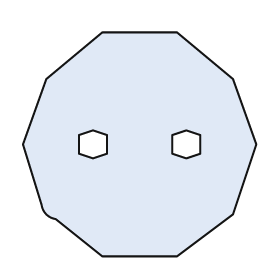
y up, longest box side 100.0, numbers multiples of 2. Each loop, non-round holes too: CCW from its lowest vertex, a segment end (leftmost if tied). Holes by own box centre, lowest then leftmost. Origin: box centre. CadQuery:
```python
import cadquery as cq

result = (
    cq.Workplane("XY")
    .moveTo(-16.0, -48.0)
    .lineTo(16.0, -48.0)
    .lineTo(40.0, -30.0)
    .lineTo(50.0, 0.0)
    .lineTo(40.0, 28.0)
    .lineTo(16.0, 48.0)
    .lineTo(-16.0, 48.0)
    .lineTo(-40.0, 28.0)
    .lineTo(-50.0, 0.0)
    .lineTo(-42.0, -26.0)
    .threePointArc((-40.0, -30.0), (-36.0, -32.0))
    .close()
    .moveTo(-20.0, -6.0)
    .lineTo(-14.0, -4.0)
    .lineTo(-14.0, 4.0)
    .lineTo(-20.0, 6.0)
    .lineTo(-26.0, 4.0)
    .lineTo(-26.0, -4.0)
    .close()
    .moveTo(20.0, -6.0)
    .lineTo(26.0, -4.0)
    .lineTo(26.0, 4.0)
    .lineTo(20.0, 6.0)
    .lineTo(14.0, 4.0)
    .lineTo(14.0, -4.0)
    .close()
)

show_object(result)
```